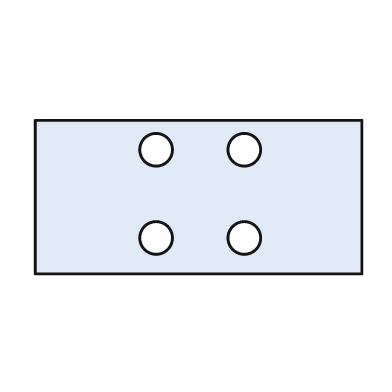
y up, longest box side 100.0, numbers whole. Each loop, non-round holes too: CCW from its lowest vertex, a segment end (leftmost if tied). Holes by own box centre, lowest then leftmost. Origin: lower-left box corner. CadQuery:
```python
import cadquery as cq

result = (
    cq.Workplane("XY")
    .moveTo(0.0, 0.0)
    .lineTo(100.0, 0.0)
    .lineTo(100.0, 47.0)
    .lineTo(0.0, 47.0)
    .close()
    .moveTo(37.0, 11.0)
    .circle(5.0)
    .moveTo(64.0, 11.0)
    .circle(5.0)
    .moveTo(37.0, 38.0)
    .circle(5.0)
    .moveTo(64.0, 38.0)
    .circle(5.0)
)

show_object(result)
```